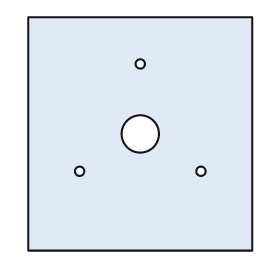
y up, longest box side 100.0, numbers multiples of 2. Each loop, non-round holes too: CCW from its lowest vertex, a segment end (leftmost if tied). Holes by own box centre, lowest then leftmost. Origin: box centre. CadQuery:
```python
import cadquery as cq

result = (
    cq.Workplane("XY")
    .moveTo(-48.0, -50.0)
    .lineTo(48.0, -50.0)
    .lineTo(48.0, 50.0)
    .lineTo(-48.0, 50.0)
    .close()
    .moveTo(-26.0, -16.0)
    .circle(2.0)
    .moveTo(26.0, -16.0)
    .circle(2.0)
    .moveTo(0.0, 0.0)
    .circle(8.0)
    .moveTo(0.0, 30.0)
    .circle(2.0)
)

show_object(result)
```